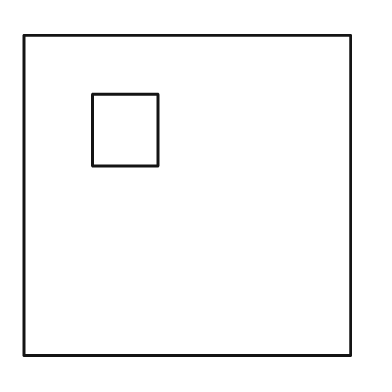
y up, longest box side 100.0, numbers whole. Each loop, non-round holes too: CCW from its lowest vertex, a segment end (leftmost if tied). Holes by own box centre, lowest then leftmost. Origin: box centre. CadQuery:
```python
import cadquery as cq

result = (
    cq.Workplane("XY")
    .moveTo(-50.0, -49.0)
    .lineTo(50.0, -49.0)
    .lineTo(50.0, 49.0)
    .lineTo(-50.0, 49.0)
    .close()
    .moveTo(-29.0, 9.0)
    .lineTo(-9.0, 9.0)
    .lineTo(-9.0, 31.0)
    .lineTo(-29.0, 31.0)
    .close()
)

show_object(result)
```